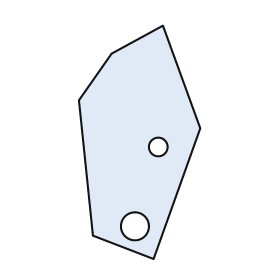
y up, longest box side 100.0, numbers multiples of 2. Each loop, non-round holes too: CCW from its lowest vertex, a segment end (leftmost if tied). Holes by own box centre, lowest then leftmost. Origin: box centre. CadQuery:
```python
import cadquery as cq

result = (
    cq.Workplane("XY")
    .moveTo(6.0, -50.0)
    .lineTo(26.0, 6.0)
    .lineTo(10.0, 50.0)
    .lineTo(-12.0, 38.0)
    .lineTo(-26.0, 18.0)
    .lineTo(-20.0, -40.0)
    .close()
    .moveTo(-2.0, -36.0)
    .circle(6.0)
    .moveTo(8.0, -2.0)
    .circle(4.0)
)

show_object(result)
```